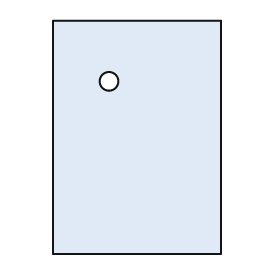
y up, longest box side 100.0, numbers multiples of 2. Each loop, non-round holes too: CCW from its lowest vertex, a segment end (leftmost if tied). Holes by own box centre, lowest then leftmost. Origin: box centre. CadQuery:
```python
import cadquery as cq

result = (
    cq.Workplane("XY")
    .moveTo(-36.0, -50.0)
    .lineTo(36.0, -50.0)
    .lineTo(36.0, 50.0)
    .lineTo(-36.0, 50.0)
    .close()
    .moveTo(-12.0, 24.0)
    .circle(4.0)
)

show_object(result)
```